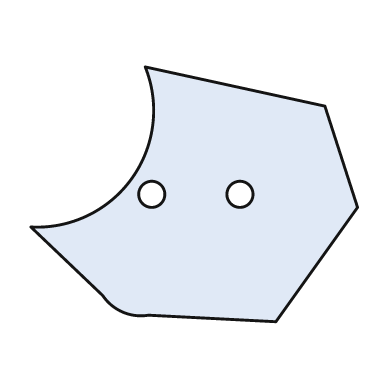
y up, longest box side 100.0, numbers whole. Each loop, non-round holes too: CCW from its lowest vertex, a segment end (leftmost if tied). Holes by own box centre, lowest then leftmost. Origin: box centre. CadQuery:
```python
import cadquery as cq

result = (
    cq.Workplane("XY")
    .moveTo(25.0, -39.0)
    .lineTo(50.0, -4.0)
    .lineTo(40.0, 27.0)
    .lineTo(-15.0, 39.0)
    .threePointArc((-19.0, 5.0), (-50.0, -10.0))
    .lineTo(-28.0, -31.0)
    .threePointArc((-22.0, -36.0), (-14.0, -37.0))
    .close()
    .moveTo(-13.0, 0.0)
    .circle(4.0)
    .moveTo(14.0, 0.0)
    .circle(4.0)
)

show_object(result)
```